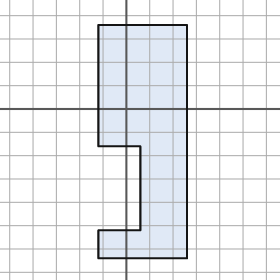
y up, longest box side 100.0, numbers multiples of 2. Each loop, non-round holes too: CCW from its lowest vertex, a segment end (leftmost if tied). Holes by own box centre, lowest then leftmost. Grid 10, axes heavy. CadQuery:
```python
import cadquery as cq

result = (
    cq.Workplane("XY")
    .moveTo(-12.0, -64.0)
    .lineTo(26.0, -64.0)
    .lineTo(26.0, 36.0)
    .lineTo(-12.0, 36.0)
    .lineTo(-12.0, -16.0)
    .lineTo(6.0, -16.0)
    .lineTo(6.0, -52.0)
    .lineTo(-12.0, -52.0)
    .close()
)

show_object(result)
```